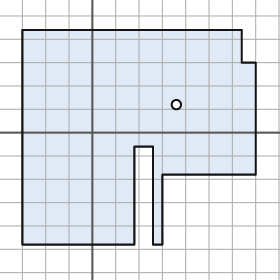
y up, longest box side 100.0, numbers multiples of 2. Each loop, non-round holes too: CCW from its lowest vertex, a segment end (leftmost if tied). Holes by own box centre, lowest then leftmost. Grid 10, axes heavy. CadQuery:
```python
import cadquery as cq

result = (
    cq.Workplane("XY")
    .moveTo(-30.0, -48.0)
    .lineTo(18.0, -48.0)
    .lineTo(18.0, -6.0)
    .lineTo(26.0, -6.0)
    .lineTo(26.0, -48.0)
    .lineTo(30.0, -48.0)
    .lineTo(30.0, -18.0)
    .lineTo(70.0, -18.0)
    .lineTo(70.0, 30.0)
    .lineTo(64.0, 30.0)
    .lineTo(64.0, 44.0)
    .lineTo(-30.0, 44.0)
    .close()
    .moveTo(36.0, 12.0)
    .circle(2.0)
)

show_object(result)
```